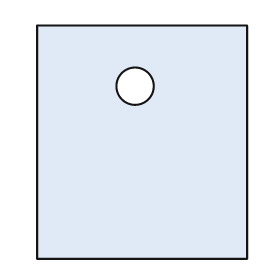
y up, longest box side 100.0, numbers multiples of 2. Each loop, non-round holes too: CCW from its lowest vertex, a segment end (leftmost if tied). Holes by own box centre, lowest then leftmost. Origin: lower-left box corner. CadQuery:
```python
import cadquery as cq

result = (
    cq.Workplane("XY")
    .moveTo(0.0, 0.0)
    .lineTo(90.0, 0.0)
    .lineTo(90.0, 100.0)
    .lineTo(0.0, 100.0)
    .close()
    .moveTo(42.0, 74.0)
    .circle(8.0)
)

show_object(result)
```